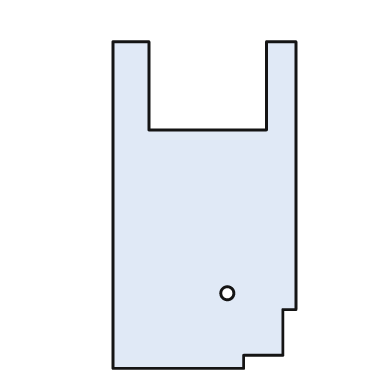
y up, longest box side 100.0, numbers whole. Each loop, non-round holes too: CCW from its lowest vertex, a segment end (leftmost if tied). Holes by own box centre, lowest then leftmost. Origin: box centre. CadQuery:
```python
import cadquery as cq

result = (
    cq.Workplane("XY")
    .moveTo(-28.0, -50.0)
    .lineTo(12.0, -50.0)
    .lineTo(12.0, -46.0)
    .lineTo(24.0, -46.0)
    .lineTo(24.0, -32.0)
    .lineTo(28.0, -32.0)
    .lineTo(28.0, 50.0)
    .lineTo(19.0, 50.0)
    .lineTo(19.0, 23.0)
    .lineTo(-17.0, 23.0)
    .lineTo(-17.0, 50.0)
    .lineTo(-28.0, 50.0)
    .close()
    .moveTo(7.0, -27.0)
    .circle(2.0)
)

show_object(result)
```